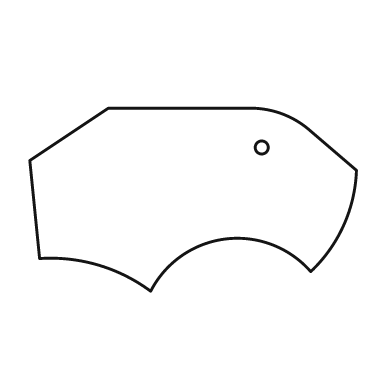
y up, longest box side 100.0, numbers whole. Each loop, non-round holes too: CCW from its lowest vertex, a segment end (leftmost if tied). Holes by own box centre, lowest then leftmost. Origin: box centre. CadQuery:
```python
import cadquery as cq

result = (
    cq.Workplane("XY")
    .moveTo(-13.0, -28.0)
    .threePointArc((10.0, -12.0), (36.0, -22.0))
    .threePointArc((46.0, -8.0), (50.0, 9.0))
    .lineTo(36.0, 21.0)
    .threePointArc((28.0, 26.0), (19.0, 28.0))
    .lineTo(-26.0, 28.0)
    .lineTo(-50.0, 12.0)
    .lineTo(-47.0, -18.0)
    .threePointArc((-29.0, -20.0), (-13.0, -28.0))
    .close()
    .moveTo(21.0, 16.0)
    .circle(2.0)
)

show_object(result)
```